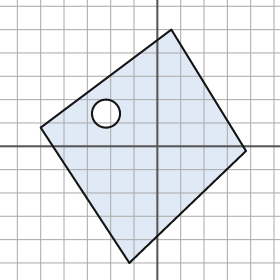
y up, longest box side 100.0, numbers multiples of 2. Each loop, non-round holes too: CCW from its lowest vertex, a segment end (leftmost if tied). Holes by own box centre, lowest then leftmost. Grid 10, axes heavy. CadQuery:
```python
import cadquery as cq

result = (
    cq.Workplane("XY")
    .moveTo(-12.0, -50.0)
    .lineTo(38.0, -2.0)
    .lineTo(6.0, 50.0)
    .lineTo(-50.0, 8.0)
    .close()
    .moveTo(-22.0, 14.0)
    .circle(6.0)
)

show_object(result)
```